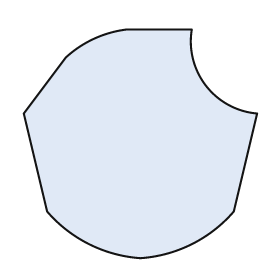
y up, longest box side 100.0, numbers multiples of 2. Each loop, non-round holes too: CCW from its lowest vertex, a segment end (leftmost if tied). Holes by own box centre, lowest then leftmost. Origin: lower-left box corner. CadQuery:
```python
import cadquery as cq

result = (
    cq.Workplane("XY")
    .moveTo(50.0, 0.0)
    .threePointArc((72.0, 6.0), (90.0, 20.0))
    .lineTo(100.0, 62.0)
    .threePointArc((78.0, 74.0), (72.0, 98.0))
    .lineTo(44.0, 98.0)
    .threePointArc((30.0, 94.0), (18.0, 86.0))
    .lineTo(0.0, 62.0)
    .lineTo(10.0, 20.0)
    .threePointArc((28.0, 6.0), (50.0, 0.0))
    .close()
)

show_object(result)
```